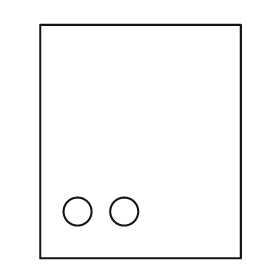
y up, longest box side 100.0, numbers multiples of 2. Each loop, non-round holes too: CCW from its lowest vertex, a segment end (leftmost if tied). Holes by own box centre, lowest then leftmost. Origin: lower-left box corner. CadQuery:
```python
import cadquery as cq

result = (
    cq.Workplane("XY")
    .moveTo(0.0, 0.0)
    .lineTo(86.0, 0.0)
    .lineTo(86.0, 100.0)
    .lineTo(0.0, 100.0)
    .close()
    .moveTo(16.0, 20.0)
    .circle(6.0)
    .moveTo(36.0, 20.0)
    .circle(6.0)
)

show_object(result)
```